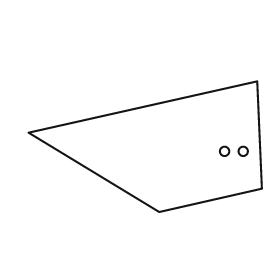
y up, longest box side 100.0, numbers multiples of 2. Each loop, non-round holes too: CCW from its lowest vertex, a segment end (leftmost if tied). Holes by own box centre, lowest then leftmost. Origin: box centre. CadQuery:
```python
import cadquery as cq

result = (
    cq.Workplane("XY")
    .moveTo(6.0, -28.0)
    .lineTo(50.0, -18.0)
    .lineTo(48.0, 28.0)
    .lineTo(-50.0, 6.0)
    .close()
    .moveTo(34.0, -2.0)
    .circle(2.0)
    .moveTo(42.0, -2.0)
    .circle(2.0)
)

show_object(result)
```